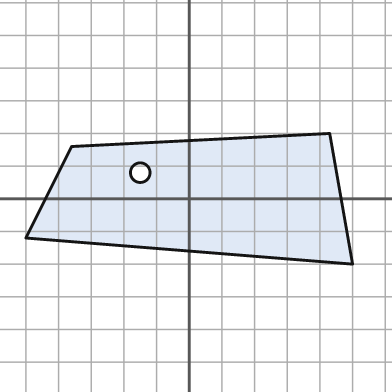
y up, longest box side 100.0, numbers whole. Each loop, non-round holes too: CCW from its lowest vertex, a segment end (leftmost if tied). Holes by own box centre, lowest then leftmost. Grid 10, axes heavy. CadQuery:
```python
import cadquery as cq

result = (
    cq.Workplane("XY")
    .moveTo(50.0, -20.0)
    .lineTo(43.0, 20.0)
    .lineTo(-36.0, 16.0)
    .lineTo(-50.0, -12.0)
    .close()
    .moveTo(-15.0, 8.0)
    .circle(3.0)
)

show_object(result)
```